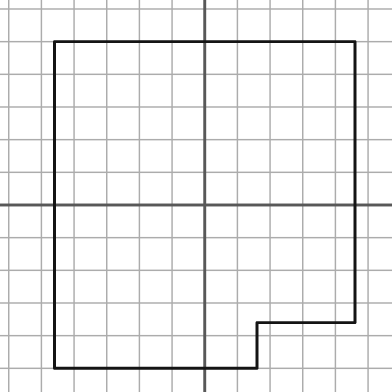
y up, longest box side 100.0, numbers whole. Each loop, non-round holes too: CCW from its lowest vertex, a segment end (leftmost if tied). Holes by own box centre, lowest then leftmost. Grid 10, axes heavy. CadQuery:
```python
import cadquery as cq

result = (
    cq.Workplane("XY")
    .moveTo(-46.0, -50.0)
    .lineTo(16.0, -50.0)
    .lineTo(16.0, -36.0)
    .lineTo(46.0, -36.0)
    .lineTo(46.0, 50.0)
    .lineTo(-46.0, 50.0)
    .close()
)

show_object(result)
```